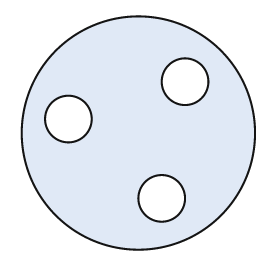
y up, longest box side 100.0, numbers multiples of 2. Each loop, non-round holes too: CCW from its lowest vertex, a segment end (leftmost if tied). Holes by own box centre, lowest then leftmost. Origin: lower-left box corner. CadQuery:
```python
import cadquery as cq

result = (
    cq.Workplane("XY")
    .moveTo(50.0, 50.0)
    .circle(50.0)
    .moveTo(60.0, 22.0)
    .circle(10.0)
    .moveTo(20.0, 56.0)
    .circle(10.0)
    .moveTo(70.0, 72.0)
    .circle(10.0)
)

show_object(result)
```